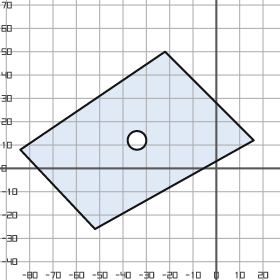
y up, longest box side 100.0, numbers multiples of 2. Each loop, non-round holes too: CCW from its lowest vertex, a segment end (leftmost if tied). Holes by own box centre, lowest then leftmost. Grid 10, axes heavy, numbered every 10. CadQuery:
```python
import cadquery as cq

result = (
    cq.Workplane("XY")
    .moveTo(-52.0, -26.0)
    .lineTo(16.0, 12.0)
    .lineTo(-22.0, 50.0)
    .lineTo(-84.0, 8.0)
    .close()
    .moveTo(-34.0, 12.0)
    .circle(4.0)
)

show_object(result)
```